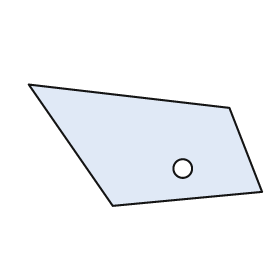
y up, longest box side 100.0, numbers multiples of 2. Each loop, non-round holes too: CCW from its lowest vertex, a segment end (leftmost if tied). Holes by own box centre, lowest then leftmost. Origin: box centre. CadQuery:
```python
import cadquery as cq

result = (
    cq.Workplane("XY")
    .moveTo(-14.0, -26.0)
    .lineTo(50.0, -20.0)
    .lineTo(36.0, 16.0)
    .lineTo(-50.0, 26.0)
    .close()
    .moveTo(16.0, -10.0)
    .circle(4.0)
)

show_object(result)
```